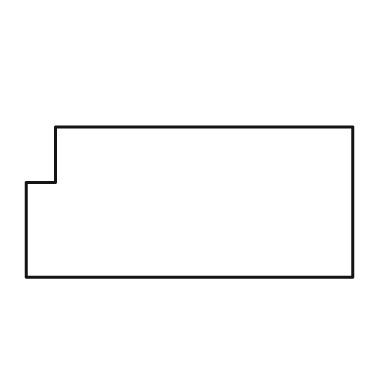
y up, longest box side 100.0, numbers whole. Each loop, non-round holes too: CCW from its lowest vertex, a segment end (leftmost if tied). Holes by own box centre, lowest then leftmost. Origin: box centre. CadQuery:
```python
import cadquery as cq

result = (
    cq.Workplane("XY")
    .moveTo(-50.0, -23.0)
    .lineTo(50.0, -23.0)
    .lineTo(50.0, 23.0)
    .lineTo(-41.0, 23.0)
    .lineTo(-41.0, 6.0)
    .lineTo(-50.0, 6.0)
    .close()
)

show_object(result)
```